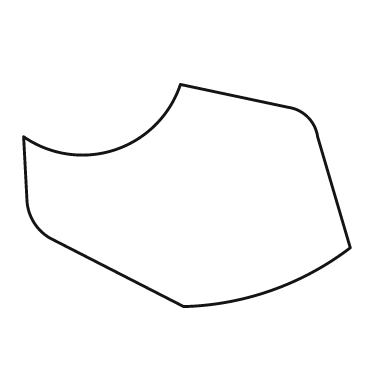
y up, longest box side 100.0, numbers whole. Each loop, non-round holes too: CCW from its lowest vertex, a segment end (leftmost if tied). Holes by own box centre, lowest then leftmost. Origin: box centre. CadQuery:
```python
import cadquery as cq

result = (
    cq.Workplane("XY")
    .moveTo(-1.0, -34.0)
    .threePointArc((26.0, -29.0), (50.0, -16.0))
    .lineTo(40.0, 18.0)
    .threePointArc((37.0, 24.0), (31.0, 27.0))
    .lineTo(-2.0, 34.0)
    .threePointArc((-22.0, 14.0), (-50.0, 18.0))
    .lineTo(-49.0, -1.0)
    .threePointArc((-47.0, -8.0), (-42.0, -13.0))
    .close()
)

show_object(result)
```